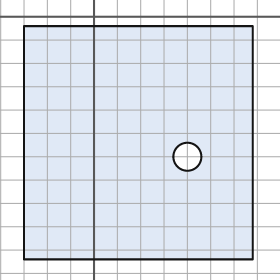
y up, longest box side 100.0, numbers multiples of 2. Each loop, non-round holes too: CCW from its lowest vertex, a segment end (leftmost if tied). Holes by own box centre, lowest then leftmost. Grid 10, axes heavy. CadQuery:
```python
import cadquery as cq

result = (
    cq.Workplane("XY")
    .moveTo(-30.0, -104.0)
    .lineTo(68.0, -104.0)
    .lineTo(68.0, -4.0)
    .lineTo(-30.0, -4.0)
    .close()
    .moveTo(40.0, -60.0)
    .circle(6.0)
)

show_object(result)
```